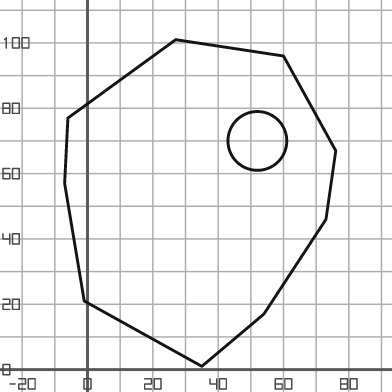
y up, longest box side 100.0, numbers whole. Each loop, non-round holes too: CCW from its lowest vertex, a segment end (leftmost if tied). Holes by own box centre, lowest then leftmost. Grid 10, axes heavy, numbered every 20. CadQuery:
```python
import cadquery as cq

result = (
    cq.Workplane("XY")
    .moveTo(35.0, 1.0)
    .lineTo(54.0, 17.0)
    .lineTo(73.0, 46.0)
    .lineTo(76.0, 67.0)
    .lineTo(60.0, 96.0)
    .lineTo(27.0, 101.0)
    .lineTo(-6.0, 77.0)
    .lineTo(-7.0, 57.0)
    .lineTo(-1.0, 21.0)
    .close()
    .moveTo(52.0, 70.0)
    .circle(9.0)
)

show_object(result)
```